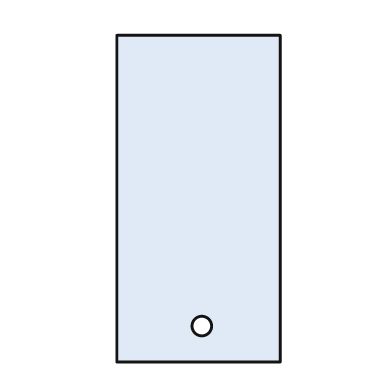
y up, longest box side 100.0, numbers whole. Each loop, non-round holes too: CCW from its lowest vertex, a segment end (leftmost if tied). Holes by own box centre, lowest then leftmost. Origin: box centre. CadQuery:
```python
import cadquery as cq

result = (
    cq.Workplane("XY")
    .moveTo(-25.0, -50.0)
    .lineTo(25.0, -50.0)
    .lineTo(25.0, 50.0)
    .lineTo(-25.0, 50.0)
    .close()
    .moveTo(1.0, -39.0)
    .circle(3.0)
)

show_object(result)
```